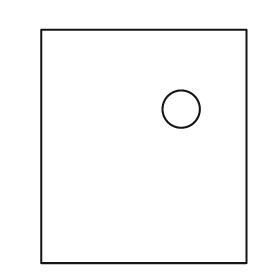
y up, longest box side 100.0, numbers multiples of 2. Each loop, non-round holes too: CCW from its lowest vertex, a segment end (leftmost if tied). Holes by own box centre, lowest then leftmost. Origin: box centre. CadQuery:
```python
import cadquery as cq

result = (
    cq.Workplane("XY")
    .moveTo(-44.0, -50.0)
    .lineTo(44.0, -50.0)
    .lineTo(44.0, 50.0)
    .lineTo(-44.0, 50.0)
    .close()
    .moveTo(16.0, 16.0)
    .circle(8.0)
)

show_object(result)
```